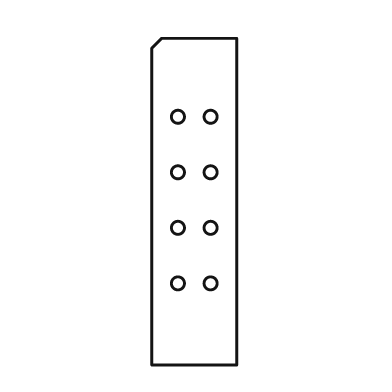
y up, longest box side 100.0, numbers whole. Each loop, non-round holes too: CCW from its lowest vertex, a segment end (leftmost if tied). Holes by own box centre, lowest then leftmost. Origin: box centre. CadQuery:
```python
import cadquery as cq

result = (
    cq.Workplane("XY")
    .moveTo(-13.0, -50.0)
    .lineTo(13.0, -50.0)
    .lineTo(13.0, 50.0)
    .lineTo(-10.0, 50.0)
    .lineTo(-13.0, 47.0)
    .close()
    .moveTo(-5.0, -25.0)
    .circle(2.0)
    .moveTo(5.0, -25.0)
    .circle(2.0)
    .moveTo(-5.0, -8.0)
    .circle(2.0)
    .moveTo(5.0, -8.0)
    .circle(2.0)
    .moveTo(-5.0, 9.0)
    .circle(2.0)
    .moveTo(5.0, 9.0)
    .circle(2.0)
    .moveTo(-5.0, 26.0)
    .circle(2.0)
    .moveTo(5.0, 26.0)
    .circle(2.0)
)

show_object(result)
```